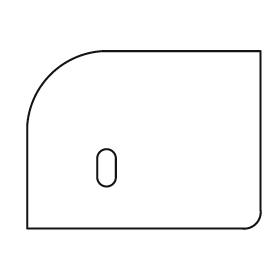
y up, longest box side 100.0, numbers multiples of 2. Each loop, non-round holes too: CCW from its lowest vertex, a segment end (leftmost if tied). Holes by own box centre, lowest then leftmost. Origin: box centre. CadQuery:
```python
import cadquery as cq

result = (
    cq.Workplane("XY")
    .moveTo(-50.0, -38.0)
    .lineTo(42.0, -38.0)
    .threePointArc((48.0, -36.0), (50.0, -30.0))
    .lineTo(50.0, 38.0)
    .lineTo(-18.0, 38.0)
    .threePointArc((-40.0, 28.0), (-50.0, 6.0))
    .close()
    .moveTo(-20.0, -16.0)
    .threePointArc((-16.0, -20.0), (-12.0, -16.0))
    .lineTo(-12.0, -8.0)
    .threePointArc((-16.0, -4.0), (-20.0, -8.0))
    .close()
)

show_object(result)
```